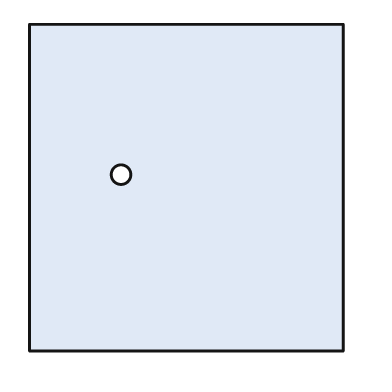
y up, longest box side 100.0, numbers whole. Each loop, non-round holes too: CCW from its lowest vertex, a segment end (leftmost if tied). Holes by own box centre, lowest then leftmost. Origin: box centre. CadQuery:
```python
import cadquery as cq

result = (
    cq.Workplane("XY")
    .moveTo(-48.0, -50.0)
    .lineTo(48.0, -50.0)
    .lineTo(48.0, 50.0)
    .lineTo(-48.0, 50.0)
    .close()
    .moveTo(-20.0, 4.0)
    .circle(3.0)
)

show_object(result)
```